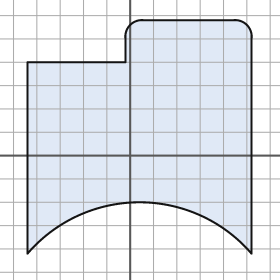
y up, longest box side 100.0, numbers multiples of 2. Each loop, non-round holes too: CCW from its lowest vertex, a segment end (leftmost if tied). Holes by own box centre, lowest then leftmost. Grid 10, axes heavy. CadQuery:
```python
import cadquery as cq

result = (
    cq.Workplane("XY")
    .moveTo(-44.0, -42.0)
    .threePointArc((4.0, -20.0), (52.0, -42.0))
    .lineTo(52.0, 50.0)
    .threePointArc((50.0, 56.0), (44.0, 58.0))
    .lineTo(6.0, 58.0)
    .threePointArc((0.0, 56.0), (-2.0, 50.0))
    .lineTo(-2.0, 40.0)
    .lineTo(-44.0, 40.0)
    .close()
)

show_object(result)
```